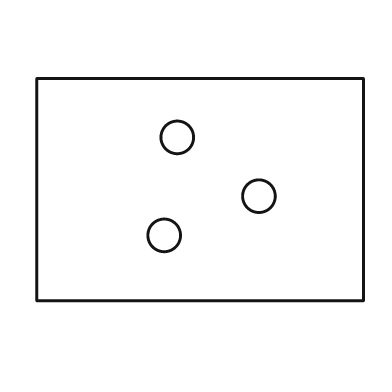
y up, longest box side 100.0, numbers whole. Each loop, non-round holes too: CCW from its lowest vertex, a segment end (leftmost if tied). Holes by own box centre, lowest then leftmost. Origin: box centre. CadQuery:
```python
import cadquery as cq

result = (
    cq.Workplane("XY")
    .moveTo(-50.0, -34.0)
    .lineTo(50.0, -34.0)
    .lineTo(50.0, 34.0)
    .lineTo(-50.0, 34.0)
    .close()
    .moveTo(-11.0, -14.0)
    .circle(5.0)
    .moveTo(18.0, -2.0)
    .circle(5.0)
    .moveTo(-7.0, 16.0)
    .circle(5.0)
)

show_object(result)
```